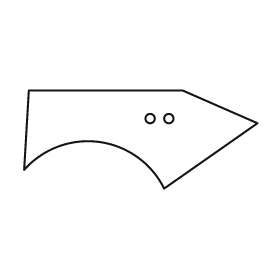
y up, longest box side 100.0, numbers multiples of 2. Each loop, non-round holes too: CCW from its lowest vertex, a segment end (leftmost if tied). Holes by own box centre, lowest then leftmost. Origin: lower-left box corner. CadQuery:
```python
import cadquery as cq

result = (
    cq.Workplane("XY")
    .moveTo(60.0, 0.0)
    .lineTo(100.0, 28.0)
    .lineTo(68.0, 42.0)
    .lineTo(2.0, 42.0)
    .lineTo(0.0, 8.0)
    .threePointArc((32.0, 20.0), (60.0, 0.0))
    .close()
    .moveTo(54.0, 30.0)
    .circle(2.0)
    .moveTo(62.0, 30.0)
    .circle(2.0)
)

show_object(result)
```